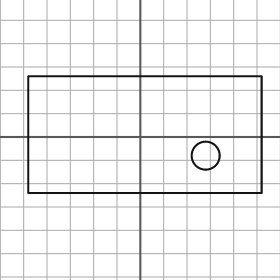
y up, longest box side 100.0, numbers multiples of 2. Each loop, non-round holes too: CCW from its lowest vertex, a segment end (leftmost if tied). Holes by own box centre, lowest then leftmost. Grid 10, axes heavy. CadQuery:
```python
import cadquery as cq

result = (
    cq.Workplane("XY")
    .moveTo(-48.0, -24.0)
    .lineTo(52.0, -24.0)
    .lineTo(52.0, 26.0)
    .lineTo(-48.0, 26.0)
    .close()
    .moveTo(28.0, -8.0)
    .circle(6.0)
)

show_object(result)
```